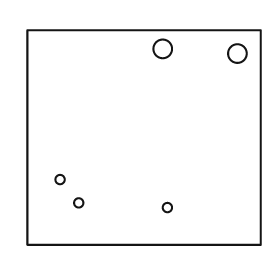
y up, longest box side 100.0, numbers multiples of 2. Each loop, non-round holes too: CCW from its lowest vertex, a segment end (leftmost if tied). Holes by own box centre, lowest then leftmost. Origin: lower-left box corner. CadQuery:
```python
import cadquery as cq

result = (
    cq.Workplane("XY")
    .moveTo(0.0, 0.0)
    .lineTo(100.0, 0.0)
    .lineTo(100.0, 92.0)
    .lineTo(0.0, 92.0)
    .close()
    .moveTo(60.0, 16.0)
    .circle(2.0)
    .moveTo(22.0, 18.0)
    .circle(2.0)
    .moveTo(14.0, 28.0)
    .circle(2.0)
    .moveTo(90.0, 82.0)
    .circle(4.0)
    .moveTo(58.0, 84.0)
    .circle(4.0)
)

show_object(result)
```